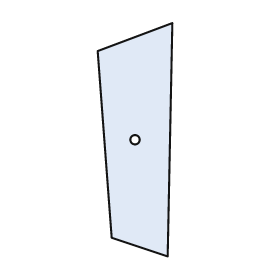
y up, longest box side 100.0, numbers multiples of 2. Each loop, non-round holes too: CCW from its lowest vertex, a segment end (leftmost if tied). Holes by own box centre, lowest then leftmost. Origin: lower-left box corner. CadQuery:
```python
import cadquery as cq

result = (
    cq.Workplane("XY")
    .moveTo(30.0, 0.0)
    .lineTo(32.0, 100.0)
    .lineTo(0.0, 88.0)
    .lineTo(6.0, 8.0)
    .close()
    .moveTo(16.0, 50.0)
    .circle(2.0)
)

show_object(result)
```